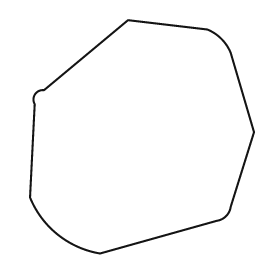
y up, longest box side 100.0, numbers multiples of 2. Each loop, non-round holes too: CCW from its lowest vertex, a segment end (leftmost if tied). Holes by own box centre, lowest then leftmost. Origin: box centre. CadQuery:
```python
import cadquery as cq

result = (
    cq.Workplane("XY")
    .moveTo(-18.0, -50.0)
    .lineTo(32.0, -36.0)
    .threePointArc((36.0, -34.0), (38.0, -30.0))
    .lineTo(48.0, 2.0)
    .lineTo(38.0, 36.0)
    .threePointArc((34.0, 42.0), (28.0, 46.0))
    .lineTo(-6.0, 50.0)
    .lineTo(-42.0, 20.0)
    .threePointArc((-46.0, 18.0), (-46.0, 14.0))
    .lineTo(-48.0, -26.0)
    .threePointArc((-36.0, -42.0), (-18.0, -50.0))
    .close()
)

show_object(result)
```